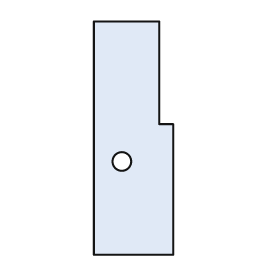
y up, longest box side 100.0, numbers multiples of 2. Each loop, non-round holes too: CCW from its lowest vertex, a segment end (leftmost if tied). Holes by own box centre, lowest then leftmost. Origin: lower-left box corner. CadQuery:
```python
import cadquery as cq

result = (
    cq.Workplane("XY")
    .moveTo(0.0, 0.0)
    .lineTo(34.0, 0.0)
    .lineTo(34.0, 56.0)
    .lineTo(28.0, 56.0)
    .lineTo(28.0, 100.0)
    .lineTo(0.0, 100.0)
    .close()
    .moveTo(12.0, 40.0)
    .circle(4.0)
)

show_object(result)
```